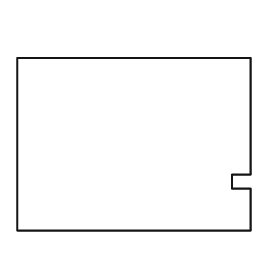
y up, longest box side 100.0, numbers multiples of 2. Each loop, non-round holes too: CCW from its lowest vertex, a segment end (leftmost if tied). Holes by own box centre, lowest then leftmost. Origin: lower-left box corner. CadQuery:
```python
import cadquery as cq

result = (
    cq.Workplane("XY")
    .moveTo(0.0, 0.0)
    .lineTo(100.0, 0.0)
    .lineTo(100.0, 18.0)
    .lineTo(92.0, 18.0)
    .lineTo(92.0, 24.0)
    .lineTo(100.0, 24.0)
    .lineTo(100.0, 74.0)
    .lineTo(0.0, 74.0)
    .close()
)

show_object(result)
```